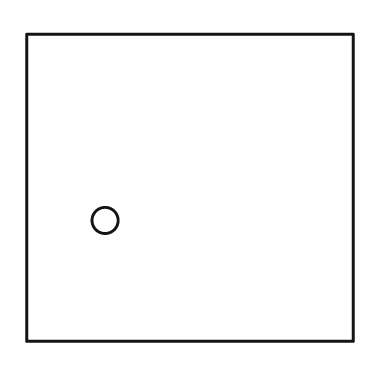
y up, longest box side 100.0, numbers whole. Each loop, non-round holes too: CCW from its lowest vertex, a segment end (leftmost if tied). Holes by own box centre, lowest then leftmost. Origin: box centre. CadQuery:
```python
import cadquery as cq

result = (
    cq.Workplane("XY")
    .moveTo(-50.0, -47.0)
    .lineTo(50.0, -47.0)
    .lineTo(50.0, 47.0)
    .lineTo(-50.0, 47.0)
    .close()
    .moveTo(-26.0, -10.0)
    .circle(4.0)
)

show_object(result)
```